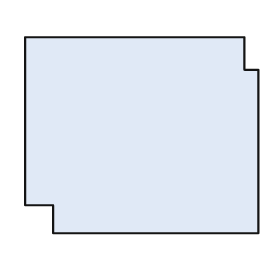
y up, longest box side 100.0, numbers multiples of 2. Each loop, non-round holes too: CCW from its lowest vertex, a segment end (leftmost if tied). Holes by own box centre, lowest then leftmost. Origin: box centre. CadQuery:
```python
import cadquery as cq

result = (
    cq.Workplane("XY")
    .moveTo(-38.0, -42.0)
    .lineTo(50.0, -42.0)
    .lineTo(50.0, 28.0)
    .lineTo(44.0, 28.0)
    .lineTo(44.0, 42.0)
    .lineTo(-50.0, 42.0)
    .lineTo(-50.0, -30.0)
    .lineTo(-38.0, -30.0)
    .close()
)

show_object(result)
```